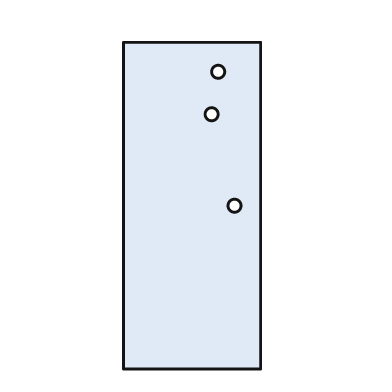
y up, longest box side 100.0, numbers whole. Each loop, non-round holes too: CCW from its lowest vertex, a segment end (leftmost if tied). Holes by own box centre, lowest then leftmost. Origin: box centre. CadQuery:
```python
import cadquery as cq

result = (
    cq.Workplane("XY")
    .moveTo(-21.0, -50.0)
    .lineTo(21.0, -50.0)
    .lineTo(21.0, 50.0)
    .lineTo(-21.0, 50.0)
    .close()
    .moveTo(13.0, 0.0)
    .circle(2.0)
    .moveTo(6.0, 28.0)
    .circle(2.0)
    .moveTo(8.0, 41.0)
    .circle(2.0)
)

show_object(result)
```